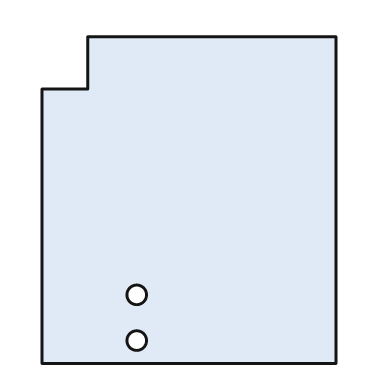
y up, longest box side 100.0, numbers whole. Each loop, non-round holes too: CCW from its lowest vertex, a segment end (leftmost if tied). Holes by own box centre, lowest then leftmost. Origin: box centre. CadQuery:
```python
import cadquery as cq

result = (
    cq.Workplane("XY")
    .moveTo(-45.0, -50.0)
    .lineTo(45.0, -50.0)
    .lineTo(45.0, 50.0)
    .lineTo(-31.0, 50.0)
    .lineTo(-31.0, 34.0)
    .lineTo(-45.0, 34.0)
    .close()
    .moveTo(-16.0, -43.0)
    .circle(3.0)
    .moveTo(-16.0, -29.0)
    .circle(3.0)
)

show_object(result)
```